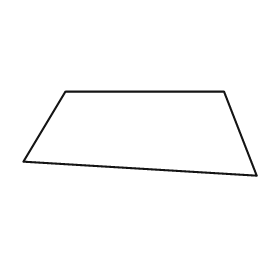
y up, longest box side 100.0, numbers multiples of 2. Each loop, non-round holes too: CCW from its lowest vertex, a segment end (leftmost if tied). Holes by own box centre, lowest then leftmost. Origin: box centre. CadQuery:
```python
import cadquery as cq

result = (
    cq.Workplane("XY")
    .moveTo(50.0, -18.0)
    .lineTo(36.0, 18.0)
    .lineTo(-32.0, 18.0)
    .lineTo(-50.0, -12.0)
    .close()
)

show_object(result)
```